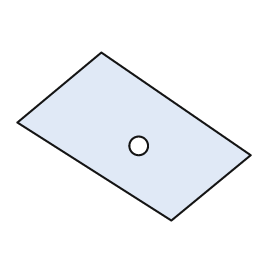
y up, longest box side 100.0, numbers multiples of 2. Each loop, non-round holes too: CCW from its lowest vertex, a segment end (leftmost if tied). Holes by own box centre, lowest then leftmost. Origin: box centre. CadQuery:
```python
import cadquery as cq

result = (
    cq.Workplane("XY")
    .moveTo(16.0, -36.0)
    .lineTo(50.0, -8.0)
    .lineTo(-14.0, 36.0)
    .lineTo(-50.0, 6.0)
    .close()
    .moveTo(2.0, -4.0)
    .circle(4.0)
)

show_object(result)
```